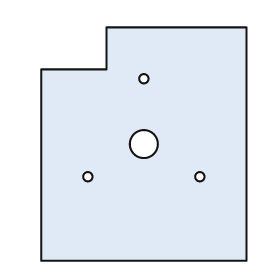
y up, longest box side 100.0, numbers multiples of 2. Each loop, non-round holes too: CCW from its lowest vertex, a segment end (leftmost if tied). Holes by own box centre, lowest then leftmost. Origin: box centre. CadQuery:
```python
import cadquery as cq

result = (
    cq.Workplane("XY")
    .moveTo(-44.0, -50.0)
    .lineTo(44.0, -50.0)
    .lineTo(44.0, 50.0)
    .lineTo(-16.0, 50.0)
    .lineTo(-16.0, 32.0)
    .lineTo(-44.0, 32.0)
    .close()
    .moveTo(-24.0, -14.0)
    .circle(2.0)
    .moveTo(24.0, -14.0)
    .circle(2.0)
    .moveTo(0.0, 0.0)
    .circle(6.0)
    .moveTo(0.0, 28.0)
    .circle(2.0)
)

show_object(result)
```